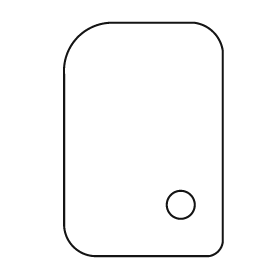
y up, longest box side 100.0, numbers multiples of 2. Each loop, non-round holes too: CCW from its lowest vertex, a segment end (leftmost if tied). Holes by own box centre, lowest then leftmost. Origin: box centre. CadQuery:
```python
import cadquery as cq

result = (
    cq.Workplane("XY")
    .moveTo(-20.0, -50.0)
    .lineTo(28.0, -50.0)
    .threePointArc((32.0, -48.0), (34.0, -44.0))
    .lineTo(34.0, 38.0)
    .threePointArc((30.0, 46.0), (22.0, 50.0))
    .lineTo(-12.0, 50.0)
    .threePointArc((-28.0, 44.0), (-34.0, 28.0))
    .lineTo(-34.0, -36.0)
    .threePointArc((-30.0, -46.0), (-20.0, -50.0))
    .close()
    .moveTo(16.0, -28.0)
    .circle(6.0)
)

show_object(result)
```